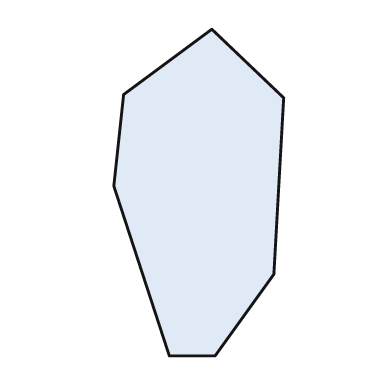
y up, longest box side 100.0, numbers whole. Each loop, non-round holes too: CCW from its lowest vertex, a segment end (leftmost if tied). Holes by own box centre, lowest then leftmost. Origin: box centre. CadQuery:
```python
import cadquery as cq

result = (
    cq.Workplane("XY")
    .moveTo(-9.0, -50.0)
    .lineTo(5.0, -50.0)
    .lineTo(23.0, -25.0)
    .lineTo(26.0, 29.0)
    .lineTo(4.0, 50.0)
    .lineTo(-23.0, 30.0)
    .lineTo(-26.0, 2.0)
    .close()
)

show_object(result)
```